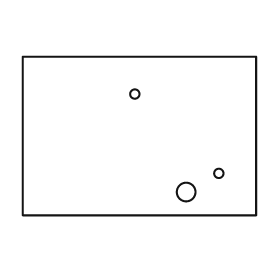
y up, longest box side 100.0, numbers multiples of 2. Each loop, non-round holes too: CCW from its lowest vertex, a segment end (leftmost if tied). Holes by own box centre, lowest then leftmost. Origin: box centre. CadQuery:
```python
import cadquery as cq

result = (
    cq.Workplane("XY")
    .moveTo(-50.0, -34.0)
    .lineTo(50.0, -34.0)
    .lineTo(50.0, 34.0)
    .lineTo(-50.0, 34.0)
    .close()
    .moveTo(20.0, -24.0)
    .circle(4.0)
    .moveTo(34.0, -16.0)
    .circle(2.0)
    .moveTo(-2.0, 18.0)
    .circle(2.0)
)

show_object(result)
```